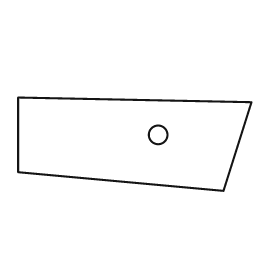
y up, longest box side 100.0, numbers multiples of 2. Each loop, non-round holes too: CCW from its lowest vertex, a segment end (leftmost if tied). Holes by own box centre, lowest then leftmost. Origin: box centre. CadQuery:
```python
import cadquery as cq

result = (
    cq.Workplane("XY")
    .moveTo(38.0, -20.0)
    .lineTo(50.0, 18.0)
    .lineTo(-50.0, 20.0)
    .lineTo(-50.0, -12.0)
    .close()
    .moveTo(10.0, 4.0)
    .circle(4.0)
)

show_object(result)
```